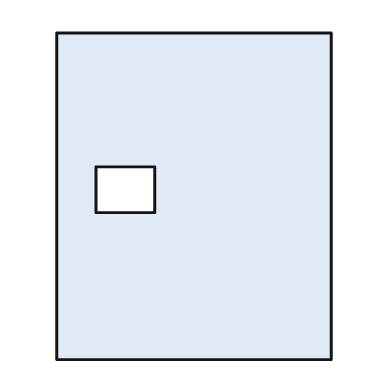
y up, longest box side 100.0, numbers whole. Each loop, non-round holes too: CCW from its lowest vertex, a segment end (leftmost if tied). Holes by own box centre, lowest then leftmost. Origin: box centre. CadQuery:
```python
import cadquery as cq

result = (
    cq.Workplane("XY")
    .moveTo(-42.0, -50.0)
    .lineTo(42.0, -50.0)
    .lineTo(42.0, 50.0)
    .lineTo(-42.0, 50.0)
    .close()
    .moveTo(-30.0, -5.0)
    .lineTo(-12.0, -5.0)
    .lineTo(-12.0, 9.0)
    .lineTo(-30.0, 9.0)
    .close()
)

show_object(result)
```